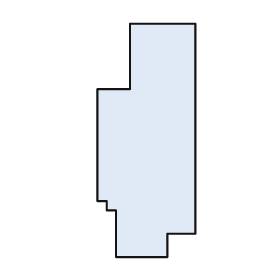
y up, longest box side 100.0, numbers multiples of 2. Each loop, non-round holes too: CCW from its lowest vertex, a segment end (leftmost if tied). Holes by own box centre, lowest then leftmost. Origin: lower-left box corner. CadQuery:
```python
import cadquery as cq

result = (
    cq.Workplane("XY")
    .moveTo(8.0, 0.0)
    .lineTo(30.0, 0.0)
    .lineTo(30.0, 10.0)
    .lineTo(42.0, 10.0)
    .lineTo(42.0, 100.0)
    .lineTo(14.0, 100.0)
    .lineTo(14.0, 72.0)
    .lineTo(0.0, 72.0)
    .lineTo(0.0, 24.0)
    .lineTo(4.0, 24.0)
    .lineTo(4.0, 20.0)
    .lineTo(8.0, 20.0)
    .close()
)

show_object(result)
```